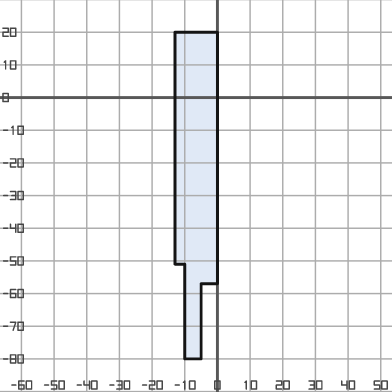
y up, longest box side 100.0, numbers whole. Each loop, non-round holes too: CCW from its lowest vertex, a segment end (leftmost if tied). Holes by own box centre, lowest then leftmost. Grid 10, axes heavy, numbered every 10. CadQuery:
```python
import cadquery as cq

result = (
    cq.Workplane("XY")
    .moveTo(-10.0, -80.0)
    .lineTo(-5.0, -80.0)
    .lineTo(-5.0, -57.0)
    .lineTo(0.0, -57.0)
    .lineTo(0.0, 20.0)
    .lineTo(-13.0, 20.0)
    .lineTo(-13.0, -51.0)
    .lineTo(-10.0, -51.0)
    .close()
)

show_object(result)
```